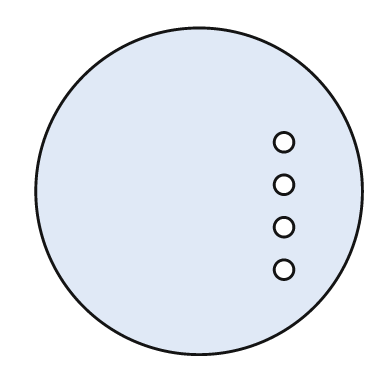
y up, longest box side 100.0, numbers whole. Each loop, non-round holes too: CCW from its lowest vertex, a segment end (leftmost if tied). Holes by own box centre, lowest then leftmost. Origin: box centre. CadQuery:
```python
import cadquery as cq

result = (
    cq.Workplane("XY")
    .moveTo(0.0, 0.0)
    .circle(50.0)
    .moveTo(26.0, -24.0)
    .circle(3.0)
    .moveTo(26.0, -11.0)
    .circle(3.0)
    .moveTo(26.0, 2.0)
    .circle(3.0)
    .moveTo(26.0, 15.0)
    .circle(3.0)
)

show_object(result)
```